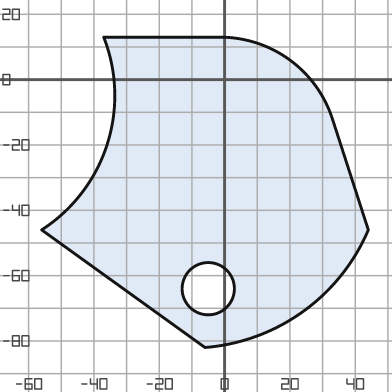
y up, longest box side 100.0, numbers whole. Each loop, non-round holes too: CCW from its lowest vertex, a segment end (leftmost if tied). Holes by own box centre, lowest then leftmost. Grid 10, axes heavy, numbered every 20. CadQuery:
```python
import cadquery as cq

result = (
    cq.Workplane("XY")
    .moveTo(-6.0, -82.0)
    .threePointArc((24.0, -71.0), (44.0, -46.0))
    .lineTo(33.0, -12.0)
    .threePointArc((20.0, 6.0), (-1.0, 13.0))
    .lineTo(-37.0, 13.0)
    .threePointArc((-36.0, -20.0), (-56.0, -46.0))
    .close()
    .moveTo(-5.0, -64.0)
    .circle(8.0)
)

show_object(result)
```